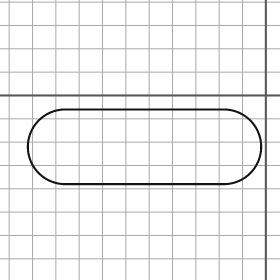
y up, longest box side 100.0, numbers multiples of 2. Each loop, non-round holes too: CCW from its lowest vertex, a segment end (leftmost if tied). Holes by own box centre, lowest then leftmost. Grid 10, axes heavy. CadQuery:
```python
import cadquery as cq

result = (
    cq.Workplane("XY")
    .moveTo(-86.0, -38.0)
    .lineTo(-18.0, -38.0)
    .threePointArc((-2.0, -22.0), (-18.0, -6.0))
    .lineTo(-86.0, -6.0)
    .threePointArc((-102.0, -22.0), (-86.0, -38.0))
    .close()
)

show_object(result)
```